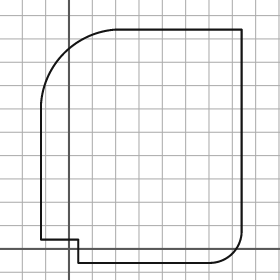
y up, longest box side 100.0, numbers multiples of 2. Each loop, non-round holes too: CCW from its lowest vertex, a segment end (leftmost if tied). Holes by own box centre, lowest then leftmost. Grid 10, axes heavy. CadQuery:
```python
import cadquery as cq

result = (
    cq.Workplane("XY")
    .moveTo(4.0, -6.0)
    .lineTo(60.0, -6.0)
    .threePointArc((70.0, -2.0), (74.0, 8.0))
    .lineTo(74.0, 94.0)
    .lineTo(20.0, 94.0)
    .threePointArc((-2.0, 84.0), (-12.0, 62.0))
    .lineTo(-12.0, 4.0)
    .lineTo(4.0, 4.0)
    .close()
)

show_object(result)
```